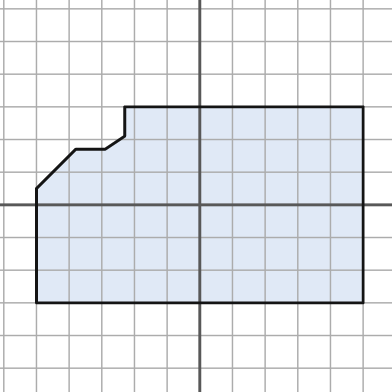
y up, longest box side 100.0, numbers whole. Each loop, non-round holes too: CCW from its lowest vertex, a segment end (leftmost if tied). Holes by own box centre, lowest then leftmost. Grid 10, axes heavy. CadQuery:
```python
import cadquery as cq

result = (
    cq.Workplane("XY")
    .moveTo(-50.0, -30.0)
    .lineTo(50.0, -30.0)
    .lineTo(50.0, 30.0)
    .lineTo(-23.0, 30.0)
    .lineTo(-23.0, 21.0)
    .lineTo(-29.0, 17.0)
    .lineTo(-38.0, 17.0)
    .lineTo(-50.0, 5.0)
    .close()
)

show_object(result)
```